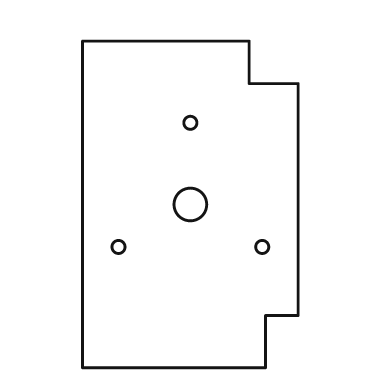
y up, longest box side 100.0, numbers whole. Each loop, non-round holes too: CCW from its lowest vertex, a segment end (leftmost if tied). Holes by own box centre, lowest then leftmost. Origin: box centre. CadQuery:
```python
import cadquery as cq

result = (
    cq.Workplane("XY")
    .moveTo(-33.0, -50.0)
    .lineTo(23.0, -50.0)
    .lineTo(23.0, -34.0)
    .lineTo(33.0, -34.0)
    .lineTo(33.0, 37.0)
    .lineTo(18.0, 37.0)
    .lineTo(18.0, 50.0)
    .lineTo(-33.0, 50.0)
    .close()
    .moveTo(-22.0, -13.0)
    .circle(2.0)
    .moveTo(22.0, -13.0)
    .circle(2.0)
    .moveTo(0.0, 0.0)
    .circle(5.0)
    .moveTo(0.0, 25.0)
    .circle(2.0)
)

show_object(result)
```